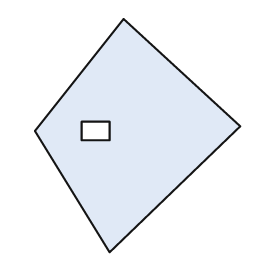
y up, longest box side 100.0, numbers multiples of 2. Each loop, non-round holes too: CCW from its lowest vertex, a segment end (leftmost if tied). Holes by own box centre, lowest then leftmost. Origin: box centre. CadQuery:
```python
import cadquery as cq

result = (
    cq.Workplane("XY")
    .moveTo(-12.0, -50.0)
    .lineTo(44.0, 4.0)
    .lineTo(-6.0, 50.0)
    .lineTo(-44.0, 2.0)
    .close()
    .moveTo(-24.0, -2.0)
    .lineTo(-12.0, -2.0)
    .lineTo(-12.0, 6.0)
    .lineTo(-24.0, 6.0)
    .close()
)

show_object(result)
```